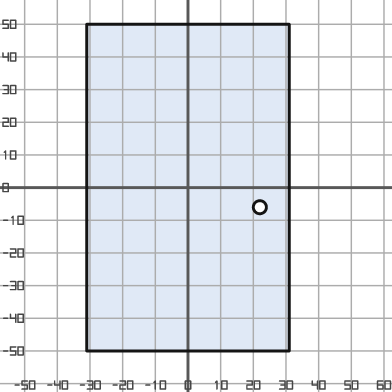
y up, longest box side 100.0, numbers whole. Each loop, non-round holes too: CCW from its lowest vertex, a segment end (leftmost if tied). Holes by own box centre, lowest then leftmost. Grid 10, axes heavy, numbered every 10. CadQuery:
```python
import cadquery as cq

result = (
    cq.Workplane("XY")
    .moveTo(-31.0, -50.0)
    .lineTo(31.0, -50.0)
    .lineTo(31.0, 50.0)
    .lineTo(-31.0, 50.0)
    .close()
    .moveTo(22.0, -6.0)
    .circle(2.0)
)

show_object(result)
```